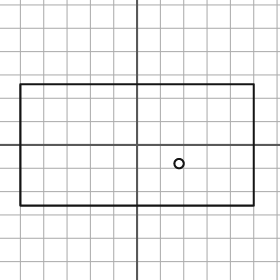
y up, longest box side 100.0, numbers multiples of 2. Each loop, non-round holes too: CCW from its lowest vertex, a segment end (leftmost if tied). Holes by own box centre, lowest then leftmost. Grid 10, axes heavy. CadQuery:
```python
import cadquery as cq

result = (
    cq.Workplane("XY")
    .moveTo(-50.0, -26.0)
    .lineTo(50.0, -26.0)
    .lineTo(50.0, 26.0)
    .lineTo(-50.0, 26.0)
    .close()
    .moveTo(18.0, -8.0)
    .circle(2.0)
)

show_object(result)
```